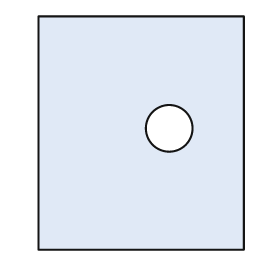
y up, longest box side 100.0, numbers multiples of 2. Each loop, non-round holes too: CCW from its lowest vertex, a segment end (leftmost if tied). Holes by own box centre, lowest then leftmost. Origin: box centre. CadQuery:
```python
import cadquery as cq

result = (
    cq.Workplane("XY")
    .moveTo(-44.0, -50.0)
    .lineTo(44.0, -50.0)
    .lineTo(44.0, 50.0)
    .lineTo(-44.0, 50.0)
    .close()
    .moveTo(12.0, 2.0)
    .circle(10.0)
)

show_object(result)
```